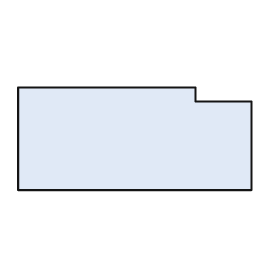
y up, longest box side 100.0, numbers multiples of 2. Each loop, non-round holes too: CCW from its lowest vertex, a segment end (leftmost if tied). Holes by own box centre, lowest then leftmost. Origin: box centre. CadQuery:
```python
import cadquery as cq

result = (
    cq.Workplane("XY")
    .moveTo(-50.0, -22.0)
    .lineTo(50.0, -22.0)
    .lineTo(50.0, 16.0)
    .lineTo(26.0, 16.0)
    .lineTo(26.0, 22.0)
    .lineTo(-50.0, 22.0)
    .close()
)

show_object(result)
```